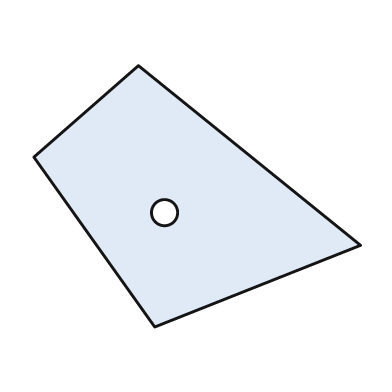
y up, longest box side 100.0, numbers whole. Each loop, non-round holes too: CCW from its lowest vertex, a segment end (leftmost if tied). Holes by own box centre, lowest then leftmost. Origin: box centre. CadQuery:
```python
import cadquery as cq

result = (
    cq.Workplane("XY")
    .moveTo(-13.0, -40.0)
    .lineTo(50.0, -15.0)
    .lineTo(-18.0, 40.0)
    .lineTo(-50.0, 12.0)
    .close()
    .moveTo(-10.0, -5.0)
    .circle(4.0)
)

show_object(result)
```